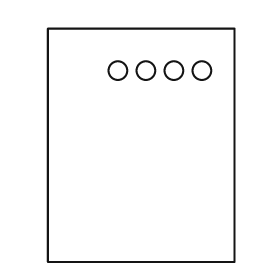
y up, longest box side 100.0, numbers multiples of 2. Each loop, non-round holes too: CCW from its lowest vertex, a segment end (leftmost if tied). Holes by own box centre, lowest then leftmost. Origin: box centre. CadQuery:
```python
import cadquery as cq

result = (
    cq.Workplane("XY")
    .moveTo(-40.0, -50.0)
    .lineTo(40.0, -50.0)
    .lineTo(40.0, 50.0)
    .lineTo(-40.0, 50.0)
    .close()
    .moveTo(-10.0, 32.0)
    .circle(4.0)
    .moveTo(2.0, 32.0)
    .circle(4.0)
    .moveTo(14.0, 32.0)
    .circle(4.0)
    .moveTo(26.0, 32.0)
    .circle(4.0)
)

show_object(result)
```